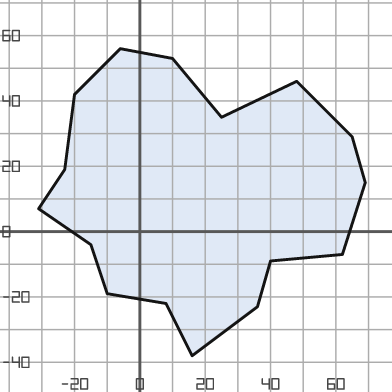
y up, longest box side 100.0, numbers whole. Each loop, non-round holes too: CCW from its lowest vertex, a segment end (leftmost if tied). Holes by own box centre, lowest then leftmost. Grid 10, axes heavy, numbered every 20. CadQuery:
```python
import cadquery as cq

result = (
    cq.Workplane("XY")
    .moveTo(16.0, -38.0)
    .lineTo(36.0, -23.0)
    .lineTo(40.0, -9.0)
    .lineTo(62.0, -7.0)
    .lineTo(69.0, 15.0)
    .lineTo(65.0, 29.0)
    .lineTo(48.0, 46.0)
    .lineTo(25.0, 35.0)
    .lineTo(10.0, 53.0)
    .lineTo(-6.0, 56.0)
    .lineTo(-20.0, 42.0)
    .lineTo(-23.0, 19.0)
    .lineTo(-31.0, 7.0)
    .lineTo(-15.0, -4.0)
    .lineTo(-10.0, -19.0)
    .lineTo(8.0, -22.0)
    .close()
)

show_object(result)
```